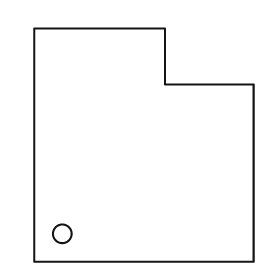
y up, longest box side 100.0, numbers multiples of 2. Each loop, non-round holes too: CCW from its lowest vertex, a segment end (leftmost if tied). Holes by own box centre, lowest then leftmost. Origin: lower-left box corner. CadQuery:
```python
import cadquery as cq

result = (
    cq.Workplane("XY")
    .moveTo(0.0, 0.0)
    .lineTo(94.0, 0.0)
    .lineTo(94.0, 76.0)
    .lineTo(56.0, 76.0)
    .lineTo(56.0, 100.0)
    .lineTo(0.0, 100.0)
    .close()
    .moveTo(12.0, 12.0)
    .circle(4.0)
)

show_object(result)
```